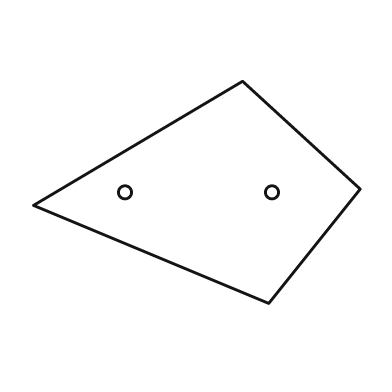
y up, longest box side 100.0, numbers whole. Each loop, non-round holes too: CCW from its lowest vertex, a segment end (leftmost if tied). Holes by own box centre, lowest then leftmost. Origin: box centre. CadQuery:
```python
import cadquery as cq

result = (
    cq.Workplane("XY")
    .moveTo(22.0, -34.0)
    .lineTo(50.0, 1.0)
    .lineTo(14.0, 34.0)
    .lineTo(-50.0, -4.0)
    .close()
    .moveTo(-22.0, 0.0)
    .circle(2.0)
    .moveTo(23.0, 0.0)
    .circle(2.0)
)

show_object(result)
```